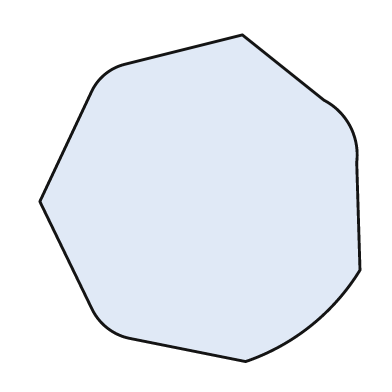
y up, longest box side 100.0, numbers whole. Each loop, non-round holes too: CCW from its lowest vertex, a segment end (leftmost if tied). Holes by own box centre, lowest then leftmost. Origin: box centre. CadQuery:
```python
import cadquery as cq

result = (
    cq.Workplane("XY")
    .moveTo(14.0, -50.0)
    .threePointArc((34.0, -39.0), (49.0, -22.0))
    .lineTo(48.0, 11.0)
    .threePointArc((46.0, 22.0), (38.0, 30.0))
    .lineTo(13.0, 50.0)
    .lineTo(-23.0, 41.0)
    .threePointArc((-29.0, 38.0), (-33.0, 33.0))
    .lineTo(-49.0, -1.0)
    .lineTo(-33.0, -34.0)
    .threePointArc((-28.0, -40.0), (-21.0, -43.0))
    .close()
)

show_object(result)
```